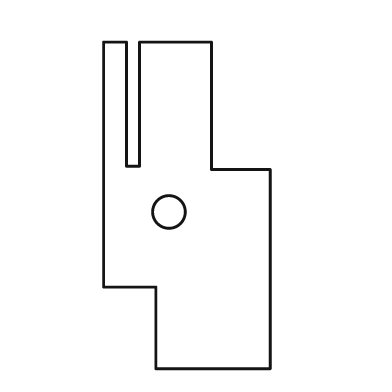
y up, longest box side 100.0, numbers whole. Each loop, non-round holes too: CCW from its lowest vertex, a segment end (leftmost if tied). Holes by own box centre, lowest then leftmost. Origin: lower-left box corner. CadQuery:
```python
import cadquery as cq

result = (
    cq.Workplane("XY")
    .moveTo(16.0, 0.0)
    .lineTo(51.0, 0.0)
    .lineTo(51.0, 61.0)
    .lineTo(33.0, 61.0)
    .lineTo(33.0, 100.0)
    .lineTo(11.0, 100.0)
    .lineTo(11.0, 62.0)
    .lineTo(7.0, 62.0)
    .lineTo(7.0, 100.0)
    .lineTo(0.0, 100.0)
    .lineTo(0.0, 25.0)
    .lineTo(16.0, 25.0)
    .close()
    .moveTo(20.0, 48.0)
    .circle(5.0)
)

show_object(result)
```